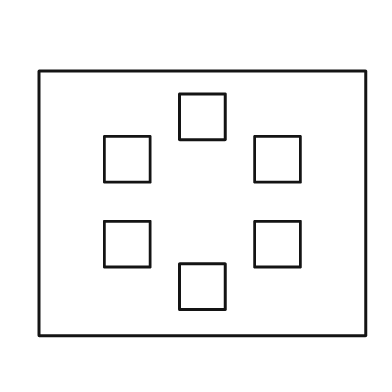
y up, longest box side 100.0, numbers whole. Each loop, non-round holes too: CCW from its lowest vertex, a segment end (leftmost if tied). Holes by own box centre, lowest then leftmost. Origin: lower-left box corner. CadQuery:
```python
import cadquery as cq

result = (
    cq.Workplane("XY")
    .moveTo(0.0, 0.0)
    .lineTo(100.0, 0.0)
    .lineTo(100.0, 81.0)
    .lineTo(0.0, 81.0)
    .close()
    .moveTo(43.0, 8.0)
    .lineTo(57.0, 8.0)
    .lineTo(57.0, 22.0)
    .lineTo(43.0, 22.0)
    .close()
    .moveTo(20.0, 21.0)
    .lineTo(34.0, 21.0)
    .lineTo(34.0, 35.0)
    .lineTo(20.0, 35.0)
    .close()
    .moveTo(66.0, 21.0)
    .lineTo(80.0, 21.0)
    .lineTo(80.0, 35.0)
    .lineTo(66.0, 35.0)
    .close()
    .moveTo(20.0, 47.0)
    .lineTo(34.0, 47.0)
    .lineTo(34.0, 61.0)
    .lineTo(20.0, 61.0)
    .close()
    .moveTo(66.0, 47.0)
    .lineTo(80.0, 47.0)
    .lineTo(80.0, 61.0)
    .lineTo(66.0, 61.0)
    .close()
    .moveTo(43.0, 60.0)
    .lineTo(57.0, 60.0)
    .lineTo(57.0, 74.0)
    .lineTo(43.0, 74.0)
    .close()
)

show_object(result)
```